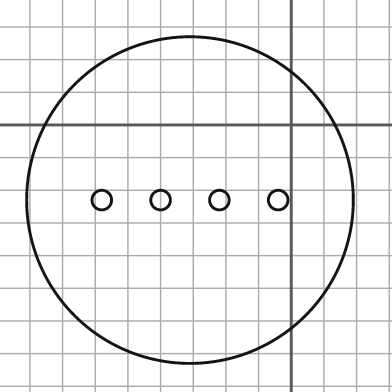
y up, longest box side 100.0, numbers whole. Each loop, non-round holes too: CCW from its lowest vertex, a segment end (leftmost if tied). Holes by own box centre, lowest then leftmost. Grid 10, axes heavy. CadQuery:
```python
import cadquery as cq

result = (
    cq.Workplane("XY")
    .moveTo(-31.0, -23.0)
    .circle(50.0)
    .moveTo(-58.0, -23.0)
    .circle(3.0)
    .moveTo(-40.0, -23.0)
    .circle(3.0)
    .moveTo(-22.0, -23.0)
    .circle(3.0)
    .moveTo(-4.0, -23.0)
    .circle(3.0)
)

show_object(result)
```